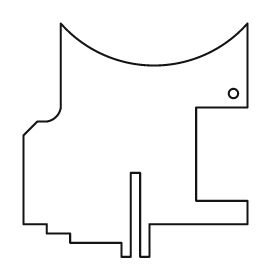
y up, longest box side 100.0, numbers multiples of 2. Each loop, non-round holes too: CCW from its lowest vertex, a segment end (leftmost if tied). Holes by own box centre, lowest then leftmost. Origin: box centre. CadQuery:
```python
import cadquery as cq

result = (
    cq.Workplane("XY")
    .moveTo(-6.0, -50.0)
    .lineTo(-2.0, -50.0)
    .lineTo(-2.0, -14.0)
    .lineTo(2.0, -14.0)
    .lineTo(2.0, -50.0)
    .lineTo(6.0, -50.0)
    .lineTo(6.0, -36.0)
    .lineTo(48.0, -36.0)
    .lineTo(48.0, -26.0)
    .lineTo(26.0, -26.0)
    .lineTo(26.0, 14.0)
    .lineTo(48.0, 14.0)
    .lineTo(48.0, 50.0)
    .threePointArc((8.0, 32.0), (-32.0, 50.0))
    .lineTo(-32.0, 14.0)
    .threePointArc((-34.0, 10.0), (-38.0, 8.0))
    .lineTo(-42.0, 8.0)
    .lineTo(-48.0, 2.0)
    .lineTo(-48.0, -36.0)
    .lineTo(-38.0, -36.0)
    .lineTo(-38.0, -40.0)
    .lineTo(-28.0, -40.0)
    .lineTo(-28.0, -44.0)
    .lineTo(-6.0, -44.0)
    .close()
    .moveTo(42.0, 20.0)
    .circle(2.0)
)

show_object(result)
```